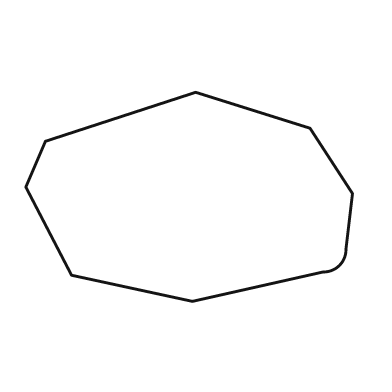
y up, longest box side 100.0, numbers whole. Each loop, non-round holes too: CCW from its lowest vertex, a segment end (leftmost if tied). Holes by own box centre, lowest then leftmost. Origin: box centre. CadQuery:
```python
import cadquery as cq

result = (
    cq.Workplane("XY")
    .moveTo(1.0, -32.0)
    .lineTo(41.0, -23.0)
    .threePointArc((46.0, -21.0), (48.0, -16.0))
    .lineTo(50.0, 1.0)
    .lineTo(37.0, 21.0)
    .lineTo(2.0, 32.0)
    .lineTo(-44.0, 17.0)
    .lineTo(-50.0, 3.0)
    .lineTo(-36.0, -24.0)
    .close()
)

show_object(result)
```